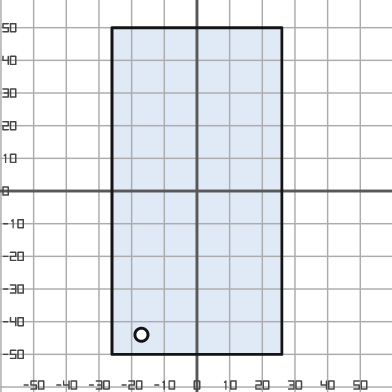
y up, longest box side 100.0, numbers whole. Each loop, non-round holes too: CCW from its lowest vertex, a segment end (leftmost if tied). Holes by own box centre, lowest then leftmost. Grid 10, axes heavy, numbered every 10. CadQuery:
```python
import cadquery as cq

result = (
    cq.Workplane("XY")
    .moveTo(-26.0, -50.0)
    .lineTo(26.0, -50.0)
    .lineTo(26.0, 50.0)
    .lineTo(-26.0, 50.0)
    .close()
    .moveTo(-17.0, -44.0)
    .circle(2.0)
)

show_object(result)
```